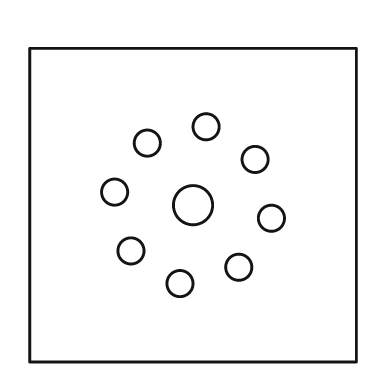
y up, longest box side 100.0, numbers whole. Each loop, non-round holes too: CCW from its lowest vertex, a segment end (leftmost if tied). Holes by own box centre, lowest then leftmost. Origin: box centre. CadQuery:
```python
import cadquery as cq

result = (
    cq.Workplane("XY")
    .moveTo(-50.0, -48.0)
    .lineTo(50.0, -48.0)
    .lineTo(50.0, 48.0)
    .lineTo(-50.0, 48.0)
    .close()
    .moveTo(-4.0, -24.0)
    .circle(4.0)
    .moveTo(14.0, -19.0)
    .circle(4.0)
    .moveTo(-19.0, -14.0)
    .circle(4.0)
    .moveTo(24.0, -4.0)
    .circle(4.0)
    .moveTo(0.0, 0.0)
    .circle(6.0)
    .moveTo(-24.0, 4.0)
    .circle(4.0)
    .moveTo(19.0, 14.0)
    .circle(4.0)
    .moveTo(-14.0, 19.0)
    .circle(4.0)
    .moveTo(4.0, 24.0)
    .circle(4.0)
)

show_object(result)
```